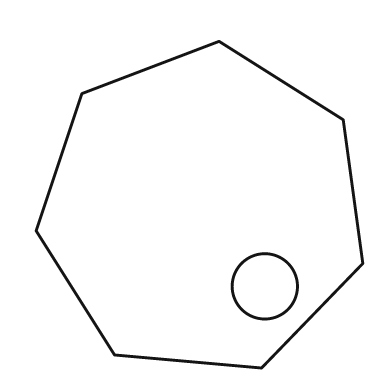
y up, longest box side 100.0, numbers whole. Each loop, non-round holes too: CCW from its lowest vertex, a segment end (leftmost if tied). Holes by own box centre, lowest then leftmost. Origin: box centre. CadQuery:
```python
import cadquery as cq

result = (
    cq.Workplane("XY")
    .moveTo(19.0, -50.0)
    .lineTo(50.0, -18.0)
    .lineTo(44.0, 26.0)
    .lineTo(6.0, 50.0)
    .lineTo(-36.0, 34.0)
    .lineTo(-50.0, -8.0)
    .lineTo(-26.0, -46.0)
    .close()
    .moveTo(20.0, -25.0)
    .circle(10.0)
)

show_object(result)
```